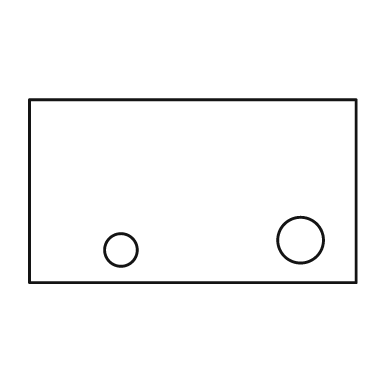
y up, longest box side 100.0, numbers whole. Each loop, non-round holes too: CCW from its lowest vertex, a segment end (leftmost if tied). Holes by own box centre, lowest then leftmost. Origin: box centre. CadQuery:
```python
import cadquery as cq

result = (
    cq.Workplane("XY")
    .moveTo(-50.0, -28.0)
    .lineTo(50.0, -28.0)
    .lineTo(50.0, 28.0)
    .lineTo(-50.0, 28.0)
    .close()
    .moveTo(-22.0, -18.0)
    .circle(5.0)
    .moveTo(33.0, -15.0)
    .circle(7.0)
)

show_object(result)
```